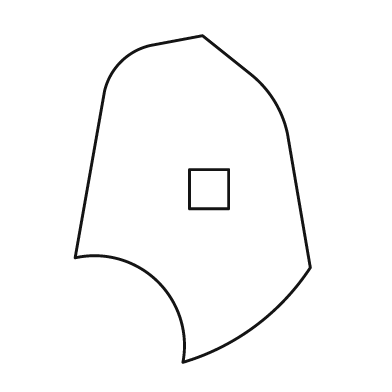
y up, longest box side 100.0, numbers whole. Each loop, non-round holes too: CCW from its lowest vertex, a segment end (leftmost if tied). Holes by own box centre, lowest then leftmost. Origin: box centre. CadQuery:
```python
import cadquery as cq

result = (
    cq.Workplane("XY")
    .moveTo(-3.0, -50.0)
    .threePointArc((19.0, -39.0), (36.0, -21.0))
    .lineTo(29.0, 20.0)
    .threePointArc((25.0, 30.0), (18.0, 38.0))
    .lineTo(3.0, 50.0)
    .lineTo(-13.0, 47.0)
    .threePointArc((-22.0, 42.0), (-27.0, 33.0))
    .lineTo(-36.0, -18.0)
    .threePointArc((-11.0, -25.0), (-3.0, -50.0))
    .close()
    .moveTo(-1.0, -3.0)
    .lineTo(11.0, -3.0)
    .lineTo(11.0, 9.0)
    .lineTo(-1.0, 9.0)
    .close()
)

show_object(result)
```